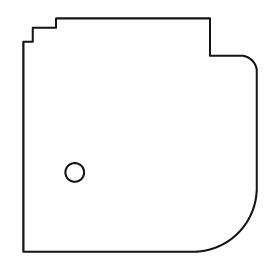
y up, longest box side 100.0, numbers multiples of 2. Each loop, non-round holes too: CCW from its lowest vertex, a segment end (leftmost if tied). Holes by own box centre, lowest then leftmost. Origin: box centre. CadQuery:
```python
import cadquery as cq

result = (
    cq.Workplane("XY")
    .moveTo(-50.0, -50.0)
    .lineTo(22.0, -50.0)
    .threePointArc((42.0, -42.0), (50.0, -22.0))
    .lineTo(50.0, 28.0)
    .threePointArc((48.0, 32.0), (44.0, 34.0))
    .lineTo(30.0, 34.0)
    .lineTo(30.0, 50.0)
    .lineTo(-36.0, 50.0)
    .lineTo(-36.0, 46.0)
    .lineTo(-46.0, 46.0)
    .lineTo(-46.0, 40.0)
    .lineTo(-50.0, 40.0)
    .close()
    .moveTo(-28.0, -16.0)
    .circle(4.0)
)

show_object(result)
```